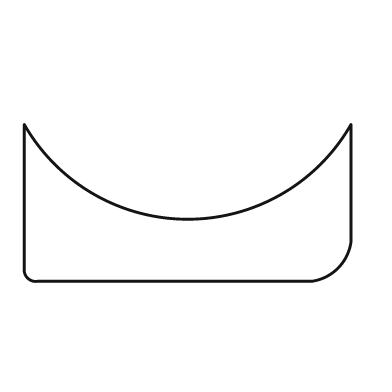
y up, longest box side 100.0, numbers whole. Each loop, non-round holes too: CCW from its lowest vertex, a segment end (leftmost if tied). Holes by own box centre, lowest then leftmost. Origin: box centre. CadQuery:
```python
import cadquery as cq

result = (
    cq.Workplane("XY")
    .moveTo(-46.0, -24.0)
    .lineTo(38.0, -24.0)
    .threePointArc((46.0, -20.0), (50.0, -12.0))
    .lineTo(50.0, 24.0)
    .threePointArc((0.0, -5.0), (-50.0, 24.0))
    .lineTo(-50.0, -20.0)
    .threePointArc((-49.0, -23.0), (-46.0, -24.0))
    .close()
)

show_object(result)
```